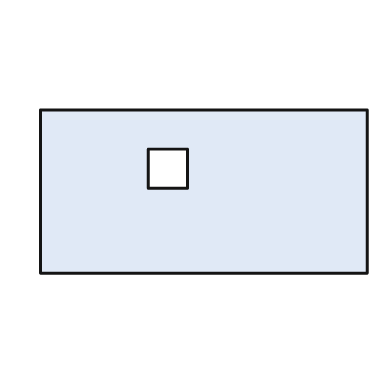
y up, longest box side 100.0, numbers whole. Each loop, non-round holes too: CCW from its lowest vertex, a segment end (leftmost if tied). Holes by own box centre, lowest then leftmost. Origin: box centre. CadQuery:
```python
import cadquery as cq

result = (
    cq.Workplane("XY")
    .moveTo(-50.0, -25.0)
    .lineTo(50.0, -25.0)
    .lineTo(50.0, 25.0)
    .lineTo(-50.0, 25.0)
    .close()
    .moveTo(-17.0, 1.0)
    .lineTo(-5.0, 1.0)
    .lineTo(-5.0, 13.0)
    .lineTo(-17.0, 13.0)
    .close()
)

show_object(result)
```